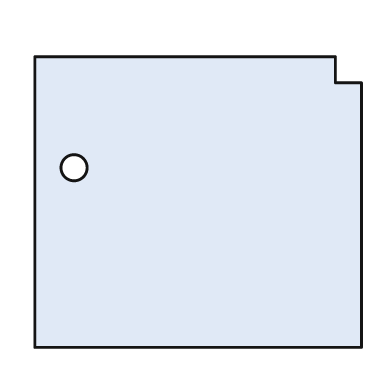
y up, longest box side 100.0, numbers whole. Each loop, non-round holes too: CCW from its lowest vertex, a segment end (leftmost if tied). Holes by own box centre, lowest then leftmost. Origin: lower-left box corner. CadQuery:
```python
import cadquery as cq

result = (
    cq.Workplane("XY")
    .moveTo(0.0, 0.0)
    .lineTo(100.0, 0.0)
    .lineTo(100.0, 81.0)
    .lineTo(92.0, 81.0)
    .lineTo(92.0, 89.0)
    .lineTo(0.0, 89.0)
    .close()
    .moveTo(12.0, 55.0)
    .circle(4.0)
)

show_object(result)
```